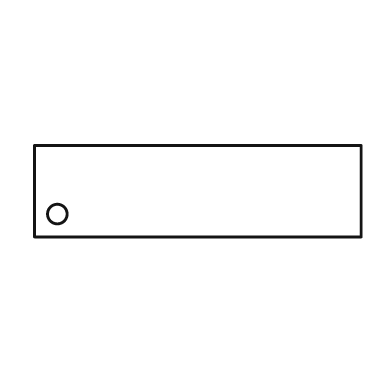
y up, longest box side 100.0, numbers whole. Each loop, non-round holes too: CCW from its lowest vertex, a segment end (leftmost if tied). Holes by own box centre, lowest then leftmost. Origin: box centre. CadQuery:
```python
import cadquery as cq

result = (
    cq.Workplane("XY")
    .moveTo(-50.0, -14.0)
    .lineTo(50.0, -14.0)
    .lineTo(50.0, 14.0)
    .lineTo(-50.0, 14.0)
    .close()
    .moveTo(-43.0, -7.0)
    .circle(3.0)
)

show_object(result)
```